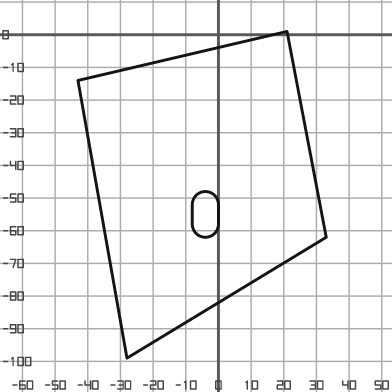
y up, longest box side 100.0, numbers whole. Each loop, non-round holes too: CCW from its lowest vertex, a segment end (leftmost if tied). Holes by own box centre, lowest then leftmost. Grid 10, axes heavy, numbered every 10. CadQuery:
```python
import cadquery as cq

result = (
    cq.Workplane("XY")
    .moveTo(-28.0, -99.0)
    .lineTo(33.0, -62.0)
    .lineTo(21.0, 1.0)
    .lineTo(-43.0, -14.0)
    .close()
    .moveTo(-8.0, -58.0)
    .threePointArc((-4.0, -62.0), (0.0, -58.0))
    .lineTo(0.0, -52.0)
    .threePointArc((-4.0, -48.0), (-8.0, -52.0))
    .close()
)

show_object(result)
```